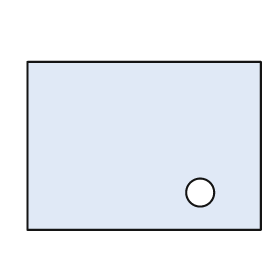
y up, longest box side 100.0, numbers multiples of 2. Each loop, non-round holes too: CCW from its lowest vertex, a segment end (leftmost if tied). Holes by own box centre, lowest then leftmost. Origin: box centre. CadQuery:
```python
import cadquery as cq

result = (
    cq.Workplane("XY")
    .moveTo(-50.0, -36.0)
    .lineTo(50.0, -36.0)
    .lineTo(50.0, 36.0)
    .lineTo(-50.0, 36.0)
    .close()
    .moveTo(24.0, -20.0)
    .circle(6.0)
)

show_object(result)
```